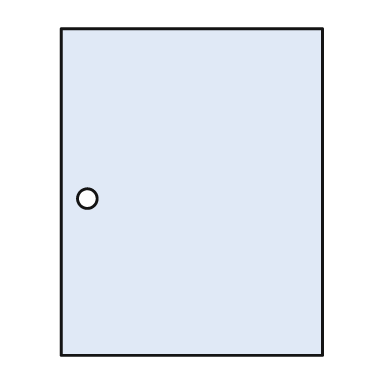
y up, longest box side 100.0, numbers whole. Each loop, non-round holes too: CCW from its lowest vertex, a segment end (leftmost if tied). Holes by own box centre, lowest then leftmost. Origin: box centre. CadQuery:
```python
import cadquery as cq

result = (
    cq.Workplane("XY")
    .moveTo(-40.0, -50.0)
    .lineTo(40.0, -50.0)
    .lineTo(40.0, 50.0)
    .lineTo(-40.0, 50.0)
    .close()
    .moveTo(-32.0, -2.0)
    .circle(3.0)
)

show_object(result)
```